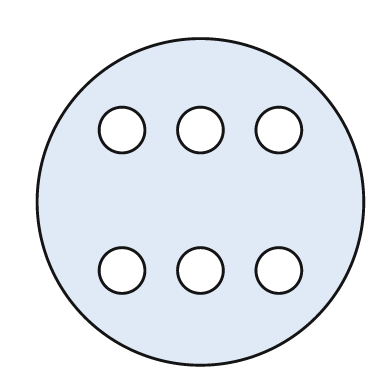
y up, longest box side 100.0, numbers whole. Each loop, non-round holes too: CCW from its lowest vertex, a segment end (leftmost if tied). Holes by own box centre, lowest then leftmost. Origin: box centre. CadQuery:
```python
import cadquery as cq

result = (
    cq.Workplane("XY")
    .moveTo(0.0, 0.0)
    .circle(50.0)
    .moveTo(-24.0, -21.0)
    .circle(7.0)
    .moveTo(0.0, -21.0)
    .circle(7.0)
    .moveTo(24.0, -21.0)
    .circle(7.0)
    .moveTo(-24.0, 22.0)
    .circle(7.0)
    .moveTo(0.0, 22.0)
    .circle(7.0)
    .moveTo(24.0, 22.0)
    .circle(7.0)
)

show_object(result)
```